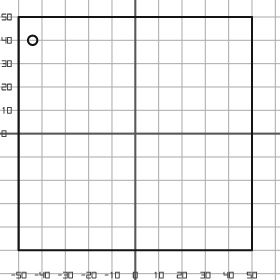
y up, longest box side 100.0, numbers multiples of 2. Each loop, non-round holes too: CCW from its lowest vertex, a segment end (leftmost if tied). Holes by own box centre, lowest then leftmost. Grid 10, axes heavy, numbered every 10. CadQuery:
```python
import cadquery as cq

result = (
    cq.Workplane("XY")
    .moveTo(-50.0, -50.0)
    .lineTo(50.0, -50.0)
    .lineTo(50.0, 50.0)
    .lineTo(-50.0, 50.0)
    .close()
    .moveTo(-44.0, 40.0)
    .circle(2.0)
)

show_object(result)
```